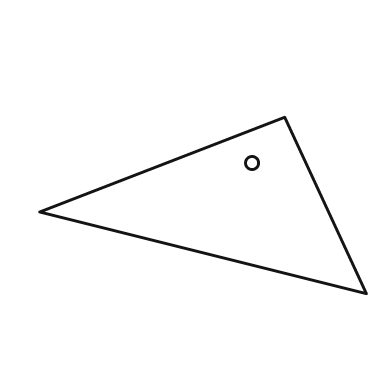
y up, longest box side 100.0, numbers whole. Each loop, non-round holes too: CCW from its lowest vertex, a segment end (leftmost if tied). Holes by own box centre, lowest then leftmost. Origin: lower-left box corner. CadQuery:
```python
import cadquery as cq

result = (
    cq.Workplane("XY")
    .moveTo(100.0, 0.0)
    .lineTo(75.0, 54.0)
    .lineTo(0.0, 25.0)
    .close()
    .moveTo(65.0, 40.0)
    .circle(2.0)
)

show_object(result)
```